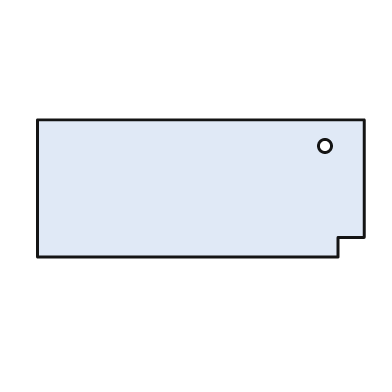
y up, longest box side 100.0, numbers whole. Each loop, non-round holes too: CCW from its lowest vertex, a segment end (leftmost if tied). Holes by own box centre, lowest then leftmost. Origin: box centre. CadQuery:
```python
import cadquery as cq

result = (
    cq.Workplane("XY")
    .moveTo(-50.0, -21.0)
    .lineTo(42.0, -21.0)
    .lineTo(42.0, -15.0)
    .lineTo(50.0, -15.0)
    .lineTo(50.0, 21.0)
    .lineTo(-50.0, 21.0)
    .close()
    .moveTo(38.0, 13.0)
    .circle(2.0)
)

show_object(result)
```